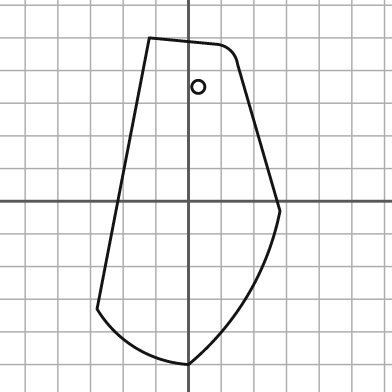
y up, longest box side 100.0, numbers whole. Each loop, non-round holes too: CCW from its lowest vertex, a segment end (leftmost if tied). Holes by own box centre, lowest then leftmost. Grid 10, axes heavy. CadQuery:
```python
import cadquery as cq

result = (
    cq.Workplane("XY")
    .moveTo(0.0, -50.0)
    .threePointArc((18.0, -29.0), (28.0, -3.0))
    .lineTo(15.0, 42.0)
    .threePointArc((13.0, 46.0), (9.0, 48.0))
    .lineTo(-12.0, 50.0)
    .lineTo(-28.0, -33.0)
    .threePointArc((-16.0, -45.0), (0.0, -50.0))
    .close()
    .moveTo(3.0, 35.0)
    .circle(2.0)
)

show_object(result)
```